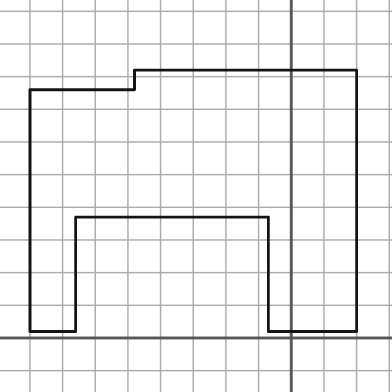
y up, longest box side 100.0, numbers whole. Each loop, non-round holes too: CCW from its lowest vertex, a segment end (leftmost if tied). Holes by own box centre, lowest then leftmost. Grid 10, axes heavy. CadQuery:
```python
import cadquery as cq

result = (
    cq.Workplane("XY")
    .moveTo(-80.0, 2.0)
    .lineTo(-66.0, 2.0)
    .lineTo(-66.0, 37.0)
    .lineTo(-7.0, 37.0)
    .lineTo(-7.0, 2.0)
    .lineTo(20.0, 2.0)
    .lineTo(20.0, 82.0)
    .lineTo(-48.0, 82.0)
    .lineTo(-48.0, 76.0)
    .lineTo(-80.0, 76.0)
    .close()
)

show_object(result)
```